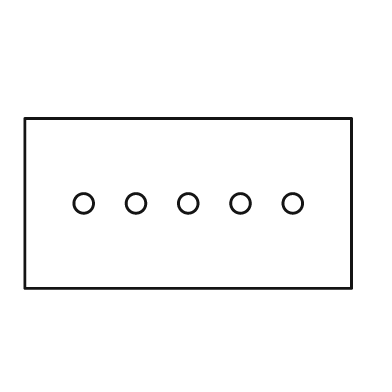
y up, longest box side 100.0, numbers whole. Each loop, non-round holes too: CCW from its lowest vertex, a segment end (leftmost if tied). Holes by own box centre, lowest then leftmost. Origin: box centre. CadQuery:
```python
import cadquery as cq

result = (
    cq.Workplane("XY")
    .moveTo(-50.0, -26.0)
    .lineTo(50.0, -26.0)
    .lineTo(50.0, 26.0)
    .lineTo(-50.0, 26.0)
    .close()
    .moveTo(-32.0, 0.0)
    .circle(3.0)
    .moveTo(-16.0, 0.0)
    .circle(3.0)
    .moveTo(0.0, 0.0)
    .circle(3.0)
    .moveTo(16.0, 0.0)
    .circle(3.0)
    .moveTo(32.0, 0.0)
    .circle(3.0)
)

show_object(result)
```